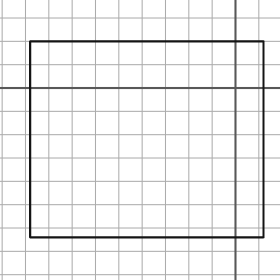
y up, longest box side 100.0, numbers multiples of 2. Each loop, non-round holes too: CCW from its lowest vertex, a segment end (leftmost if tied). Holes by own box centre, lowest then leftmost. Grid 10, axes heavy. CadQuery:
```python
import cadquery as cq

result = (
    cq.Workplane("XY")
    .moveTo(-88.0, -64.0)
    .lineTo(12.0, -64.0)
    .lineTo(12.0, 20.0)
    .lineTo(-88.0, 20.0)
    .close()
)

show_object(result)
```